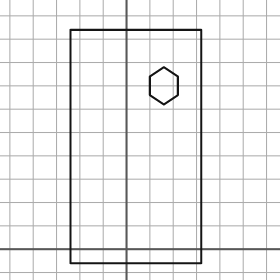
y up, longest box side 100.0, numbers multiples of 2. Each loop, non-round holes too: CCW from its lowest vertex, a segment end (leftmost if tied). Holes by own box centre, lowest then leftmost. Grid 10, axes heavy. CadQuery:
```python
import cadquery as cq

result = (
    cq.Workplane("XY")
    .moveTo(-24.0, -6.0)
    .lineTo(32.0, -6.0)
    .lineTo(32.0, 94.0)
    .lineTo(-24.0, 94.0)
    .close()
    .moveTo(16.0, 62.0)
    .lineTo(22.0, 66.0)
    .lineTo(22.0, 74.0)
    .lineTo(16.0, 78.0)
    .lineTo(10.0, 74.0)
    .lineTo(10.0, 66.0)
    .close()
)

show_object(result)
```